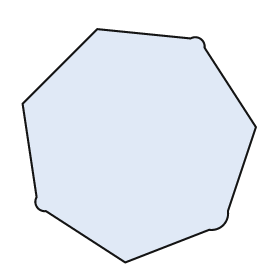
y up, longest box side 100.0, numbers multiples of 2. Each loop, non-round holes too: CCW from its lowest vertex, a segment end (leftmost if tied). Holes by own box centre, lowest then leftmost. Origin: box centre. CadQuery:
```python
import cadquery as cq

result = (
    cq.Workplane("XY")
    .moveTo(-6.0, -50.0)
    .lineTo(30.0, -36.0)
    .threePointArc((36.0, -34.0), (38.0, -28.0))
    .lineTo(50.0, 8.0)
    .lineTo(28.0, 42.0)
    .threePointArc((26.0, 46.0), (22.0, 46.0))
    .lineTo(-18.0, 50.0)
    .lineTo(-50.0, 18.0)
    .lineTo(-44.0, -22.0)
    .threePointArc((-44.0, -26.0), (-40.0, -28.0))
    .close()
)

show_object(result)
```